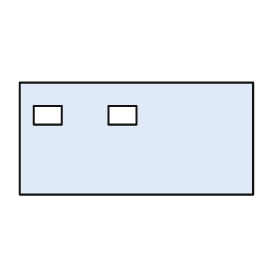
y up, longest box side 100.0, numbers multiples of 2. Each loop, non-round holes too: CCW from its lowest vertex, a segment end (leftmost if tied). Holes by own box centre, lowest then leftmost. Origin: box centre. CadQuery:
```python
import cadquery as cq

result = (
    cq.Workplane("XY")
    .moveTo(-50.0, -24.0)
    .lineTo(50.0, -24.0)
    .lineTo(50.0, 24.0)
    .lineTo(-50.0, 24.0)
    .close()
    .moveTo(-44.0, 6.0)
    .lineTo(-32.0, 6.0)
    .lineTo(-32.0, 14.0)
    .lineTo(-44.0, 14.0)
    .close()
    .moveTo(-12.0, 6.0)
    .lineTo(0.0, 6.0)
    .lineTo(0.0, 14.0)
    .lineTo(-12.0, 14.0)
    .close()
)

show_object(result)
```